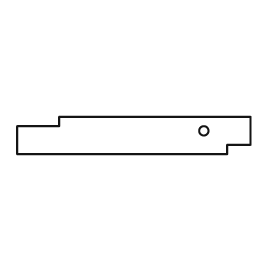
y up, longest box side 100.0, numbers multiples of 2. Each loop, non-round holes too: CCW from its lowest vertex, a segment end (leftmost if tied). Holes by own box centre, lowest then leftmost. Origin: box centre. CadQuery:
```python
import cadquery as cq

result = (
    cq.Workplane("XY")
    .moveTo(-50.0, -8.0)
    .lineTo(40.0, -8.0)
    .lineTo(40.0, -4.0)
    .lineTo(50.0, -4.0)
    .lineTo(50.0, 8.0)
    .lineTo(-32.0, 8.0)
    .lineTo(-32.0, 4.0)
    .lineTo(-50.0, 4.0)
    .close()
    .moveTo(30.0, 2.0)
    .circle(2.0)
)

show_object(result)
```